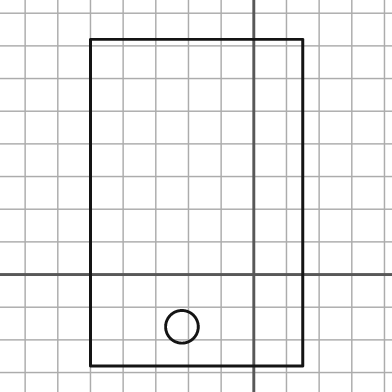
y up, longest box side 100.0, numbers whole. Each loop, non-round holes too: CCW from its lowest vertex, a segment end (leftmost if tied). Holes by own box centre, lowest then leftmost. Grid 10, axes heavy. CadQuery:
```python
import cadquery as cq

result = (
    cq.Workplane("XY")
    .moveTo(-50.0, -28.0)
    .lineTo(15.0, -28.0)
    .lineTo(15.0, 72.0)
    .lineTo(-50.0, 72.0)
    .close()
    .moveTo(-22.0, -16.0)
    .circle(5.0)
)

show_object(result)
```